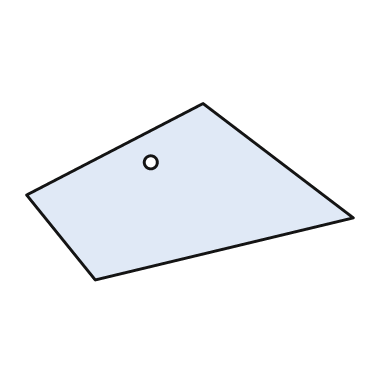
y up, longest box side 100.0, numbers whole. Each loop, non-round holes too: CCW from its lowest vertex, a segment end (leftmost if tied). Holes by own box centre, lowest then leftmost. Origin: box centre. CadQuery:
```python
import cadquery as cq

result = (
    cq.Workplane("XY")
    .moveTo(-29.0, -27.0)
    .lineTo(50.0, -8.0)
    .lineTo(4.0, 27.0)
    .lineTo(-50.0, -1.0)
    .close()
    .moveTo(-12.0, 9.0)
    .circle(2.0)
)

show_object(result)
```